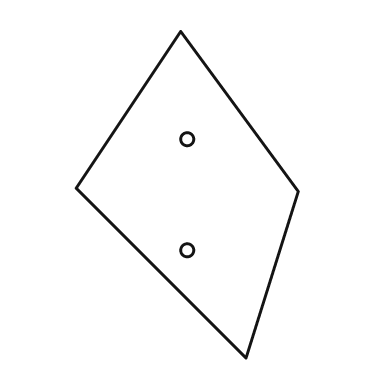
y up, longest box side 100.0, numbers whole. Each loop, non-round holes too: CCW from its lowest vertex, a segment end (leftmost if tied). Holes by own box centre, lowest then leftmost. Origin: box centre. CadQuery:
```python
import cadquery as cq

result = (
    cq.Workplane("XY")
    .moveTo(18.0, -50.0)
    .lineTo(34.0, 1.0)
    .lineTo(-2.0, 50.0)
    .lineTo(-34.0, 2.0)
    .close()
    .moveTo(0.0, -17.0)
    .circle(2.0)
    .moveTo(0.0, 17.0)
    .circle(2.0)
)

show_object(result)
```